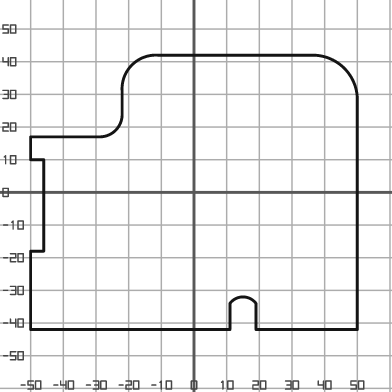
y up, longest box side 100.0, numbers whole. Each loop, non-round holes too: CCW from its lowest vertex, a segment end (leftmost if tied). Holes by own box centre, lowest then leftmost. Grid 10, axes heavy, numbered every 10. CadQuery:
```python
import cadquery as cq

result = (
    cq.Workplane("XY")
    .moveTo(-50.0, -42.0)
    .lineTo(11.0, -42.0)
    .lineTo(11.0, -34.0)
    .threePointArc((15.0, -32.0), (19.0, -34.0))
    .lineTo(19.0, -42.0)
    .lineTo(50.0, -42.0)
    .lineTo(50.0, 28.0)
    .threePointArc((46.0, 38.0), (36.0, 42.0))
    .lineTo(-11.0, 42.0)
    .threePointArc((-19.0, 39.0), (-22.0, 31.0))
    .lineTo(-22.0, 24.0)
    .threePointArc((-24.0, 19.0), (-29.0, 17.0))
    .lineTo(-50.0, 17.0)
    .lineTo(-50.0, 10.0)
    .lineTo(-46.0, 10.0)
    .lineTo(-46.0, -18.0)
    .lineTo(-50.0, -18.0)
    .close()
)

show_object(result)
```